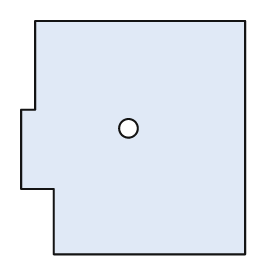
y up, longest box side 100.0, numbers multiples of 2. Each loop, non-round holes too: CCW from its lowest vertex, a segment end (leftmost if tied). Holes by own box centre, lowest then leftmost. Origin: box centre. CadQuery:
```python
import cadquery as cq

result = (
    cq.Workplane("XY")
    .moveTo(-34.0, -50.0)
    .lineTo(48.0, -50.0)
    .lineTo(48.0, 50.0)
    .lineTo(-42.0, 50.0)
    .lineTo(-42.0, 12.0)
    .lineTo(-48.0, 12.0)
    .lineTo(-48.0, -22.0)
    .lineTo(-34.0, -22.0)
    .close()
    .moveTo(-2.0, 4.0)
    .circle(4.0)
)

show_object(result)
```